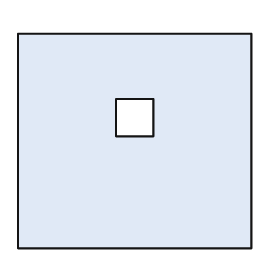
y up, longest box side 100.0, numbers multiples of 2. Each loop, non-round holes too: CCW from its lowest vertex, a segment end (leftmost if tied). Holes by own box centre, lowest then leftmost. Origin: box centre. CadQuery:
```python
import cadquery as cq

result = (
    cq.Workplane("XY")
    .moveTo(-50.0, -46.0)
    .lineTo(50.0, -46.0)
    .lineTo(50.0, 46.0)
    .lineTo(-50.0, 46.0)
    .close()
    .moveTo(-8.0, 2.0)
    .lineTo(8.0, 2.0)
    .lineTo(8.0, 18.0)
    .lineTo(-8.0, 18.0)
    .close()
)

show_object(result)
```